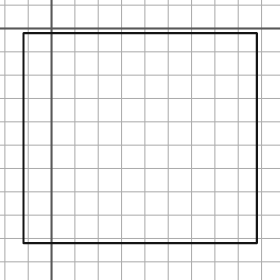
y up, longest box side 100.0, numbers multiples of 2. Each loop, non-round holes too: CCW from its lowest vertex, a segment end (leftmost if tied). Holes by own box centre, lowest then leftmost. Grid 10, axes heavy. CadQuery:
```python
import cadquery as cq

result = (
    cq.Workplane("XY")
    .moveTo(-12.0, -92.0)
    .lineTo(88.0, -92.0)
    .lineTo(88.0, -2.0)
    .lineTo(-12.0, -2.0)
    .close()
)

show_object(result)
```